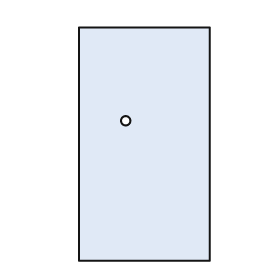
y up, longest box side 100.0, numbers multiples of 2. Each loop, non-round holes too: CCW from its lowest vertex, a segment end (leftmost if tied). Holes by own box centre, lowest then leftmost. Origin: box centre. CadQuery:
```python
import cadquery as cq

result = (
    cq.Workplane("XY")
    .moveTo(-28.0, -50.0)
    .lineTo(28.0, -50.0)
    .lineTo(28.0, 50.0)
    .lineTo(-28.0, 50.0)
    .close()
    .moveTo(-8.0, 10.0)
    .circle(2.0)
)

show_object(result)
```